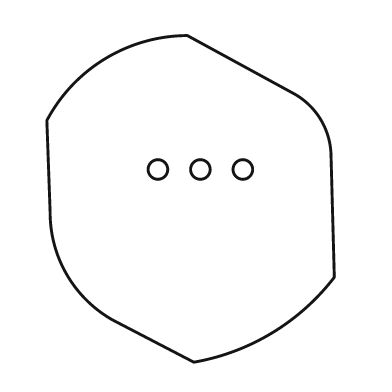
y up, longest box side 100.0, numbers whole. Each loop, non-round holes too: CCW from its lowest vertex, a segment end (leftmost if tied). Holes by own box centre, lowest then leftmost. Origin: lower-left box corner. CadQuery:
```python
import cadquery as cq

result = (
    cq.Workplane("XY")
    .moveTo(45.0, 0.0)
    .threePointArc((69.0, 9.0), (88.0, 26.0))
    .lineTo(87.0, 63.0)
    .threePointArc((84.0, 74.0), (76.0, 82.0))
    .lineTo(43.0, 100.0)
    .threePointArc((18.0, 93.0), (0.0, 74.0))
    .lineTo(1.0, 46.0)
    .threePointArc((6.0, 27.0), (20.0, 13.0))
    .close()
    .moveTo(34.0, 59.0)
    .circle(3.0)
    .moveTo(47.0, 59.0)
    .circle(3.0)
    .moveTo(60.0, 59.0)
    .circle(3.0)
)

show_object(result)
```